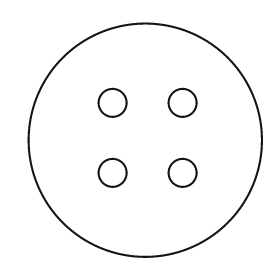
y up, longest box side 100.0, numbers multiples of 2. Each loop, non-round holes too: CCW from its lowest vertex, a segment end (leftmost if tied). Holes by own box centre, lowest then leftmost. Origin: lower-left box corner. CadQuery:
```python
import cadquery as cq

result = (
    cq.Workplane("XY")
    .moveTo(50.0, 50.0)
    .circle(50.0)
    .moveTo(36.0, 36.0)
    .circle(6.0)
    .moveTo(66.0, 36.0)
    .circle(6.0)
    .moveTo(36.0, 66.0)
    .circle(6.0)
    .moveTo(66.0, 66.0)
    .circle(6.0)
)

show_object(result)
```